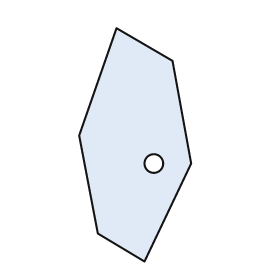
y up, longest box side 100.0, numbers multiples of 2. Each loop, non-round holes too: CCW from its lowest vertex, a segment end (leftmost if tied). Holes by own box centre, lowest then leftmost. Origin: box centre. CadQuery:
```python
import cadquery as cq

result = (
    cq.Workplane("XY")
    .moveTo(4.0, -50.0)
    .lineTo(24.0, -8.0)
    .lineTo(16.0, 36.0)
    .lineTo(-8.0, 50.0)
    .lineTo(-24.0, 4.0)
    .lineTo(-16.0, -38.0)
    .close()
    .moveTo(8.0, -8.0)
    .circle(4.0)
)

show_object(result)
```